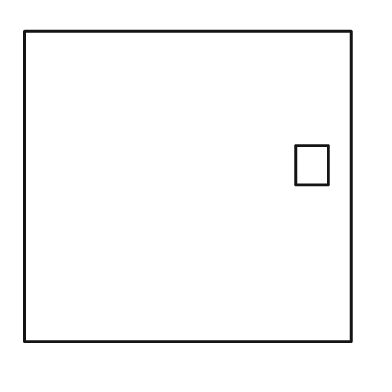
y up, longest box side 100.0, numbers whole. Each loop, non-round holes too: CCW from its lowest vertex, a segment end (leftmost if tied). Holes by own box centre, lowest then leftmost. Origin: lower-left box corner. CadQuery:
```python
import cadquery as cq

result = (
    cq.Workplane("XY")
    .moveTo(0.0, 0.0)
    .lineTo(100.0, 0.0)
    .lineTo(100.0, 95.0)
    .lineTo(0.0, 95.0)
    .close()
    .moveTo(83.0, 48.0)
    .lineTo(93.0, 48.0)
    .lineTo(93.0, 60.0)
    .lineTo(83.0, 60.0)
    .close()
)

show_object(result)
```